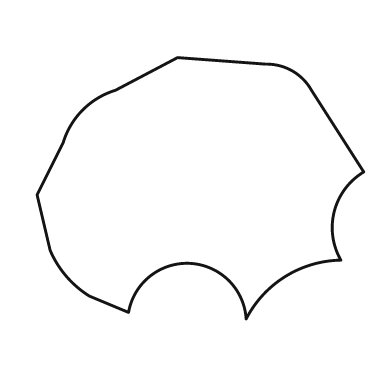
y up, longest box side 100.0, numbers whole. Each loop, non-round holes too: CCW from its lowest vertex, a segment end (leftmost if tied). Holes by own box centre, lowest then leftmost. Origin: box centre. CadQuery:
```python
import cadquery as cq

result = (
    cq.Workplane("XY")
    .moveTo(14.0, -40.0)
    .threePointArc((26.0, -27.0), (43.0, -22.0))
    .threePointArc((41.0, -7.0), (50.0, 5.0))
    .lineTo(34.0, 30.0)
    .threePointArc((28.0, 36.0), (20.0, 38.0))
    .lineTo(-7.0, 40.0)
    .lineTo(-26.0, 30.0)
    .threePointArc((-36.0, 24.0), (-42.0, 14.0))
    .lineTo(-50.0, -2.0)
    .lineTo(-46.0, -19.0)
    .threePointArc((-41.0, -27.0), (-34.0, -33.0))
    .lineTo(-22.0, -38.0)
    .threePointArc((-3.0, -23.0), (14.0, -40.0))
    .close()
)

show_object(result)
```